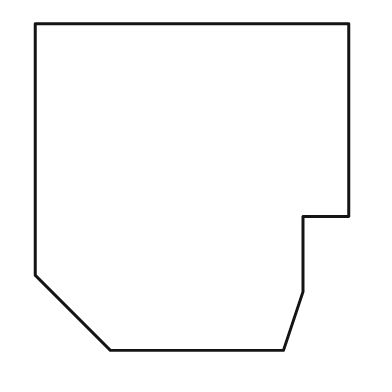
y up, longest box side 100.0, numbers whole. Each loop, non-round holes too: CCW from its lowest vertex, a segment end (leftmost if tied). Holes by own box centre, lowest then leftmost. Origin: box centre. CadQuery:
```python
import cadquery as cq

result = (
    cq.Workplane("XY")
    .moveTo(-25.0, -50.0)
    .lineTo(28.0, -50.0)
    .lineTo(34.0, -32.0)
    .lineTo(34.0, -9.0)
    .lineTo(48.0, -9.0)
    .lineTo(48.0, 50.0)
    .lineTo(-48.0, 50.0)
    .lineTo(-48.0, -27.0)
    .close()
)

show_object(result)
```